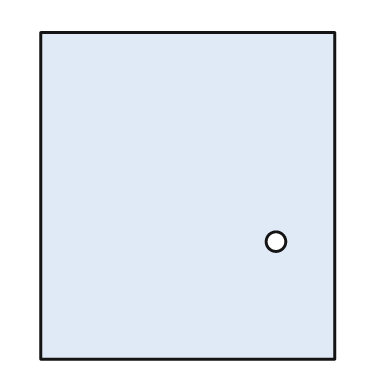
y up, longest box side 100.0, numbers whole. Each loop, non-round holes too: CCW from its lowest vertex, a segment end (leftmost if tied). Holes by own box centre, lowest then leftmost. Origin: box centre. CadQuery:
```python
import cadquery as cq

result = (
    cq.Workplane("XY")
    .moveTo(-45.0, -50.0)
    .lineTo(45.0, -50.0)
    .lineTo(45.0, 50.0)
    .lineTo(-45.0, 50.0)
    .close()
    .moveTo(27.0, -14.0)
    .circle(3.0)
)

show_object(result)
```